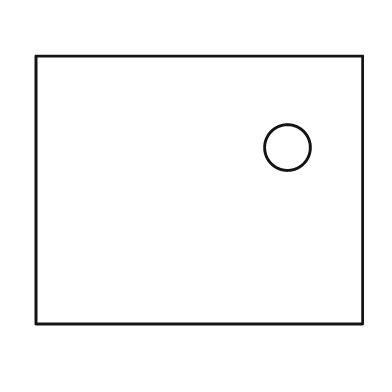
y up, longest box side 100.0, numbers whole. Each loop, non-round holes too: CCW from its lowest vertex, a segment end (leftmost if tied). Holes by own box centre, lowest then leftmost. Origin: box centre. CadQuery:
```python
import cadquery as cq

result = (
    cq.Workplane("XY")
    .moveTo(-50.0, -41.0)
    .lineTo(50.0, -41.0)
    .lineTo(50.0, 41.0)
    .lineTo(-50.0, 41.0)
    .close()
    .moveTo(27.0, 13.0)
    .circle(7.0)
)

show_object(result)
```